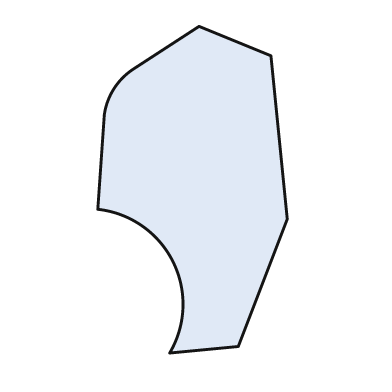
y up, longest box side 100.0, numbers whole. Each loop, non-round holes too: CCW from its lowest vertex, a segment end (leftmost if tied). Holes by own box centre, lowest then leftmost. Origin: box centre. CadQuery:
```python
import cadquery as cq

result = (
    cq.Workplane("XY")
    .moveTo(-7.0, -50.0)
    .lineTo(14.0, -48.0)
    .lineTo(29.0, -9.0)
    .lineTo(24.0, 41.0)
    .lineTo(2.0, 50.0)
    .lineTo(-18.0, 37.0)
    .threePointArc((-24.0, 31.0), (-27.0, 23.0))
    .lineTo(-29.0, -6.0)
    .threePointArc((-6.0, -22.0), (-7.0, -50.0))
    .close()
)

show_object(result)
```